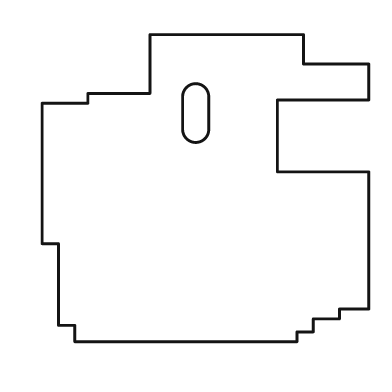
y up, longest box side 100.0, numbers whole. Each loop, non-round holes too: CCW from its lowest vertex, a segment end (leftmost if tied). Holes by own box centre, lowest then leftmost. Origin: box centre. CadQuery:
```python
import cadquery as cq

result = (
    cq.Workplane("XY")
    .moveTo(-40.0, -47.0)
    .lineTo(28.0, -47.0)
    .lineTo(28.0, -44.0)
    .lineTo(33.0, -44.0)
    .lineTo(33.0, -40.0)
    .lineTo(41.0, -40.0)
    .lineTo(41.0, -37.0)
    .lineTo(50.0, -37.0)
    .lineTo(50.0, 5.0)
    .lineTo(22.0, 5.0)
    .lineTo(22.0, 27.0)
    .lineTo(50.0, 27.0)
    .lineTo(50.0, 38.0)
    .lineTo(30.0, 38.0)
    .lineTo(30.0, 47.0)
    .lineTo(-17.0, 47.0)
    .lineTo(-17.0, 29.0)
    .lineTo(-36.0, 29.0)
    .lineTo(-36.0, 26.0)
    .lineTo(-50.0, 26.0)
    .lineTo(-50.0, -17.0)
    .lineTo(-45.0, -17.0)
    .lineTo(-45.0, -42.0)
    .lineTo(-40.0, -42.0)
    .close()
    .moveTo(-7.0, 18.0)
    .threePointArc((-3.0, 14.0), (1.0, 18.0))
    .lineTo(1.0, 28.0)
    .threePointArc((-3.0, 32.0), (-7.0, 28.0))
    .close()
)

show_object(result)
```